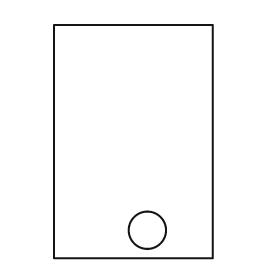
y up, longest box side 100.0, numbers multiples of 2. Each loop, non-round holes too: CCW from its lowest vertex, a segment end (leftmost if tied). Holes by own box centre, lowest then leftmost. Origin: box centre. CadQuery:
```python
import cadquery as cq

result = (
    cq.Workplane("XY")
    .moveTo(-34.0, -50.0)
    .lineTo(34.0, -50.0)
    .lineTo(34.0, 50.0)
    .lineTo(-34.0, 50.0)
    .close()
    .moveTo(6.0, -38.0)
    .circle(8.0)
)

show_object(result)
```